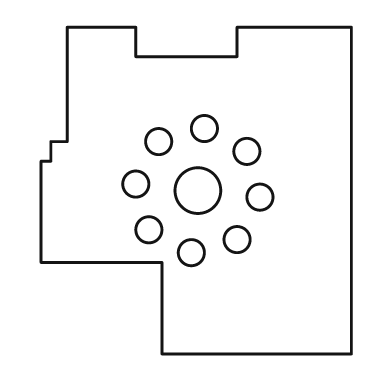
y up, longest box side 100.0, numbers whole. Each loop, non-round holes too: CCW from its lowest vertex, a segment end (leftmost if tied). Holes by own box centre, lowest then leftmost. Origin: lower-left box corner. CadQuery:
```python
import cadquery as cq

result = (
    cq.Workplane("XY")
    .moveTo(37.0, 0.0)
    .lineTo(95.0, 0.0)
    .lineTo(95.0, 100.0)
    .lineTo(60.0, 100.0)
    .lineTo(60.0, 91.0)
    .lineTo(29.0, 91.0)
    .lineTo(29.0, 100.0)
    .lineTo(8.0, 100.0)
    .lineTo(8.0, 65.0)
    .lineTo(3.0, 65.0)
    .lineTo(3.0, 59.0)
    .lineTo(0.0, 59.0)
    .lineTo(0.0, 28.0)
    .lineTo(37.0, 28.0)
    .close()
    .moveTo(46.0, 31.0)
    .circle(4.0)
    .moveTo(60.0, 35.0)
    .circle(4.0)
    .moveTo(33.0, 38.0)
    .circle(4.0)
    .moveTo(67.0, 48.0)
    .circle(4.0)
    .moveTo(48.0, 50.0)
    .circle(7.0)
    .moveTo(29.0, 52.0)
    .circle(4.0)
    .moveTo(63.0, 62.0)
    .circle(4.0)
    .moveTo(36.0, 65.0)
    .circle(4.0)
    .moveTo(50.0, 69.0)
    .circle(4.0)
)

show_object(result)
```